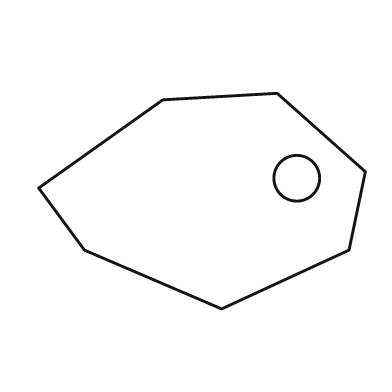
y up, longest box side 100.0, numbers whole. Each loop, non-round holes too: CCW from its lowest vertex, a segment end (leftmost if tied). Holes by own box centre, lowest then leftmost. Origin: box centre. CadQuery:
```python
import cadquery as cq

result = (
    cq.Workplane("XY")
    .moveTo(6.0, -33.0)
    .lineTo(45.0, -15.0)
    .lineTo(50.0, 9.0)
    .lineTo(23.0, 33.0)
    .lineTo(-12.0, 31.0)
    .lineTo(-50.0, 4.0)
    .lineTo(-36.0, -15.0)
    .close()
    .moveTo(29.0, 7.0)
    .circle(7.0)
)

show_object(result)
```